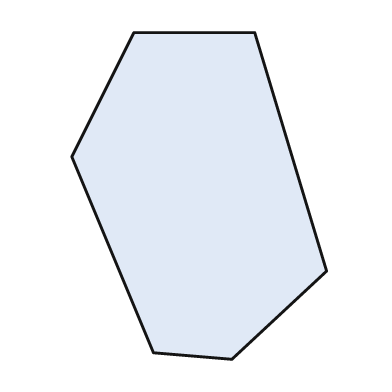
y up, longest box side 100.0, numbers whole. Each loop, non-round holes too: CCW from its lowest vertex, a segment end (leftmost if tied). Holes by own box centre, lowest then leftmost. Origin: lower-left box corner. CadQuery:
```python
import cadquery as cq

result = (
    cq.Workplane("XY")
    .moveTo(49.0, 0.0)
    .lineTo(78.0, 27.0)
    .lineTo(56.0, 100.0)
    .lineTo(19.0, 100.0)
    .lineTo(0.0, 62.0)
    .lineTo(25.0, 2.0)
    .close()
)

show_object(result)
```